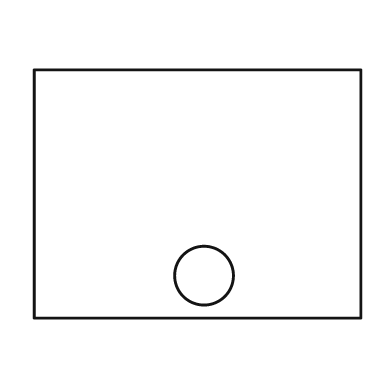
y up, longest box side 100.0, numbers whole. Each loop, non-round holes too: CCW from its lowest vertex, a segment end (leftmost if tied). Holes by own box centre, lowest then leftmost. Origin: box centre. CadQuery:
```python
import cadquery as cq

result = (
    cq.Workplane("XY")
    .moveTo(-50.0, -38.0)
    .lineTo(50.0, -38.0)
    .lineTo(50.0, 38.0)
    .lineTo(-50.0, 38.0)
    .close()
    .moveTo(2.0, -25.0)
    .circle(9.0)
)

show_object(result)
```